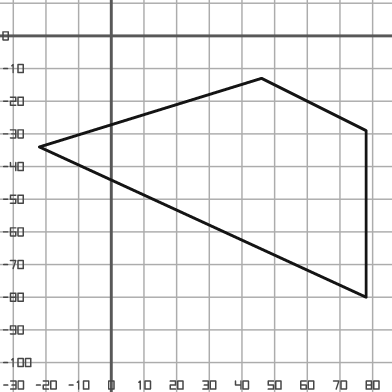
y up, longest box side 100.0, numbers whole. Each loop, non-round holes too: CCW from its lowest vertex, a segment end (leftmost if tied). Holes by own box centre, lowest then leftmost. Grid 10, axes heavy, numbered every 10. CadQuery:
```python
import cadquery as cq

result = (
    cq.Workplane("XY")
    .moveTo(78.0, -80.0)
    .lineTo(78.0, -29.0)
    .lineTo(46.0, -13.0)
    .lineTo(-22.0, -34.0)
    .close()
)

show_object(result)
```